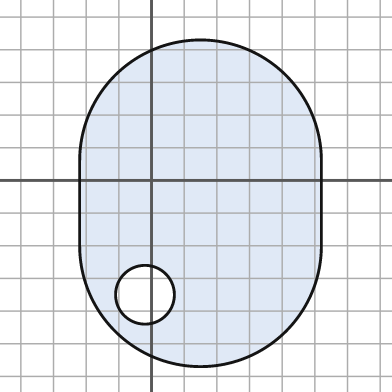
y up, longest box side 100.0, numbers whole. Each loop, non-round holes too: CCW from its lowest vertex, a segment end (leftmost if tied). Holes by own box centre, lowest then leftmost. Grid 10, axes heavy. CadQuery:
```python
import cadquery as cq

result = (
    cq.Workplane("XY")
    .moveTo(-22.0, -20.0)
    .threePointArc((15.0, -57.0), (52.0, -20.0))
    .lineTo(52.0, 6.0)
    .threePointArc((15.0, 43.0), (-22.0, 6.0))
    .close()
    .moveTo(-2.0, -35.0)
    .circle(9.0)
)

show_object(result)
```